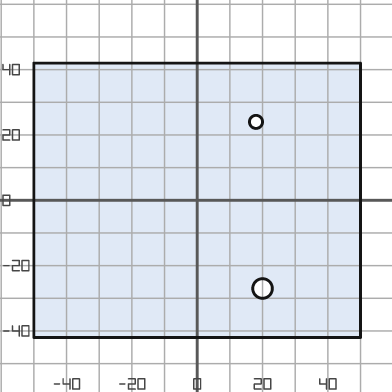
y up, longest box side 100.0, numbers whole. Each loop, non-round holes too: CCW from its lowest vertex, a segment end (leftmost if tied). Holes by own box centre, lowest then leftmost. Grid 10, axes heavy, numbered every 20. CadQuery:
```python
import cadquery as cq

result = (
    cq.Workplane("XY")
    .moveTo(-50.0, -42.0)
    .lineTo(50.0, -42.0)
    .lineTo(50.0, 42.0)
    .lineTo(-50.0, 42.0)
    .close()
    .moveTo(20.0, -27.0)
    .circle(3.0)
    .moveTo(18.0, 24.0)
    .circle(2.0)
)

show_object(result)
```